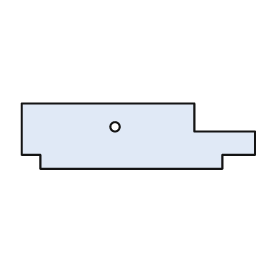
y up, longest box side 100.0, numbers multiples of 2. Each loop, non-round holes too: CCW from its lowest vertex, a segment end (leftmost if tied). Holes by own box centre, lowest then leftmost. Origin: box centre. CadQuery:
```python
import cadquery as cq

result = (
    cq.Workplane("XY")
    .moveTo(-42.0, -14.0)
    .lineTo(36.0, -14.0)
    .lineTo(36.0, -8.0)
    .lineTo(50.0, -8.0)
    .lineTo(50.0, 2.0)
    .lineTo(24.0, 2.0)
    .lineTo(24.0, 14.0)
    .lineTo(-50.0, 14.0)
    .lineTo(-50.0, -8.0)
    .lineTo(-42.0, -8.0)
    .close()
    .moveTo(-10.0, 4.0)
    .circle(2.0)
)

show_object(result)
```